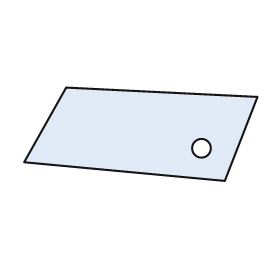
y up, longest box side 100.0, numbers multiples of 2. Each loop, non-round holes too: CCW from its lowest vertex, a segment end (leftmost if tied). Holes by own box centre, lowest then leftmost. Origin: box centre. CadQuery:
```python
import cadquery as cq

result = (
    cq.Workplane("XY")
    .moveTo(36.0, -20.0)
    .lineTo(50.0, 16.0)
    .lineTo(-32.0, 20.0)
    .lineTo(-50.0, -12.0)
    .close()
    .moveTo(26.0, -6.0)
    .circle(4.0)
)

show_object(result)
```